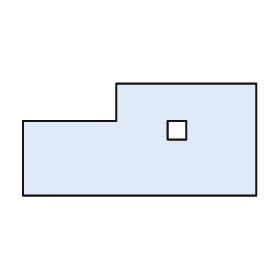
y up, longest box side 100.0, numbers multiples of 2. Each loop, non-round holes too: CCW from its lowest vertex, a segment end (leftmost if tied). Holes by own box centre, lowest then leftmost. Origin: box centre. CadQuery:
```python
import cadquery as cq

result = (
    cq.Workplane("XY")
    .moveTo(-50.0, -24.0)
    .lineTo(50.0, -24.0)
    .lineTo(50.0, 24.0)
    .lineTo(-10.0, 24.0)
    .lineTo(-10.0, 8.0)
    .lineTo(-50.0, 8.0)
    .close()
    .moveTo(12.0, 0.0)
    .lineTo(20.0, 0.0)
    .lineTo(20.0, 8.0)
    .lineTo(12.0, 8.0)
    .close()
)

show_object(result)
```